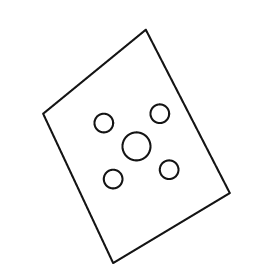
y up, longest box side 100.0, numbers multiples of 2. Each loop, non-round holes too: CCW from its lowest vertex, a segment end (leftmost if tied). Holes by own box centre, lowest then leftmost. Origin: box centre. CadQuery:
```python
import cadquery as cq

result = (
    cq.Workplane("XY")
    .moveTo(-10.0, -50.0)
    .lineTo(40.0, -20.0)
    .lineTo(4.0, 50.0)
    .lineTo(-40.0, 14.0)
    .close()
    .moveTo(-10.0, -14.0)
    .circle(4.0)
    .moveTo(14.0, -10.0)
    .circle(4.0)
    .moveTo(0.0, 0.0)
    .circle(6.0)
    .moveTo(-14.0, 10.0)
    .circle(4.0)
    .moveTo(10.0, 14.0)
    .circle(4.0)
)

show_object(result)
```